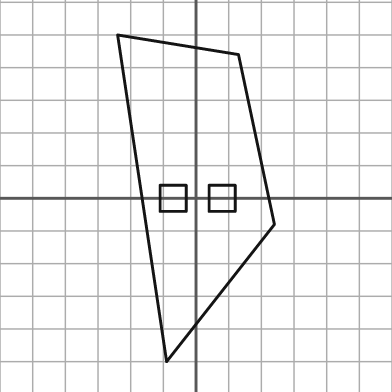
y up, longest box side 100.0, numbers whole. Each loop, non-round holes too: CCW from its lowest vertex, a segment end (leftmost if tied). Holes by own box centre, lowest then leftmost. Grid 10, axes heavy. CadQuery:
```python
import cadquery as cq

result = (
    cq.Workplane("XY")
    .moveTo(-9.0, -50.0)
    .lineTo(24.0, -8.0)
    .lineTo(13.0, 44.0)
    .lineTo(-24.0, 50.0)
    .close()
    .moveTo(-11.0, -4.0)
    .lineTo(-3.0, -4.0)
    .lineTo(-3.0, 4.0)
    .lineTo(-11.0, 4.0)
    .close()
    .moveTo(4.0, -4.0)
    .lineTo(12.0, -4.0)
    .lineTo(12.0, 4.0)
    .lineTo(4.0, 4.0)
    .close()
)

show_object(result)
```